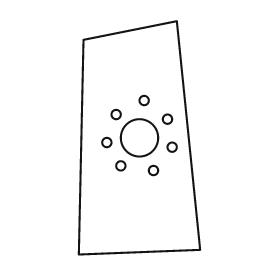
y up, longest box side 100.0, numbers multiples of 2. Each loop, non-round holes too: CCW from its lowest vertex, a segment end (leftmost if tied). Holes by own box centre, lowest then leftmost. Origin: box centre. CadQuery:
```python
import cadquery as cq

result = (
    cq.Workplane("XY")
    .moveTo(-26.0, -50.0)
    .lineTo(26.0, -48.0)
    .lineTo(16.0, 50.0)
    .lineTo(-24.0, 42.0)
    .close()
    .moveTo(6.0, -14.0)
    .circle(2.0)
    .moveTo(-8.0, -12.0)
    .circle(2.0)
    .moveTo(14.0, -4.0)
    .circle(2.0)
    .moveTo(-14.0, -2.0)
    .circle(2.0)
    .moveTo(0.0, 0.0)
    .circle(8.0)
    .moveTo(12.0, 8.0)
    .circle(2.0)
    .moveTo(-10.0, 10.0)
    .circle(2.0)
    .moveTo(2.0, 16.0)
    .circle(2.0)
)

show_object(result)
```